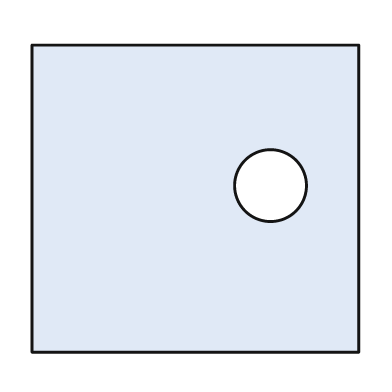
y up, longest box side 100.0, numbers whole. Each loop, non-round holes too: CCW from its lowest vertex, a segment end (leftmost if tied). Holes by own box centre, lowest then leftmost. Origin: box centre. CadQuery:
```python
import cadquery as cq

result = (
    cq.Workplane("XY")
    .moveTo(-50.0, -47.0)
    .lineTo(50.0, -47.0)
    .lineTo(50.0, 47.0)
    .lineTo(-50.0, 47.0)
    .close()
    .moveTo(23.0, 4.0)
    .circle(11.0)
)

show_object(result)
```